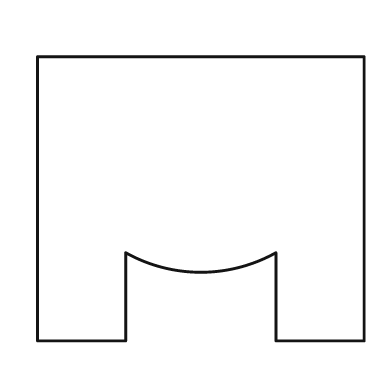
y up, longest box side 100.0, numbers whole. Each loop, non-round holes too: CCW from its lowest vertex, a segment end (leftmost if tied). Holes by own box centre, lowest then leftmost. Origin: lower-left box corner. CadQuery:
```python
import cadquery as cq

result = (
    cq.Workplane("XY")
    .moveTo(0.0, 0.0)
    .lineTo(27.0, 0.0)
    .lineTo(27.0, 27.0)
    .threePointArc((50.0, 21.0), (73.0, 27.0))
    .lineTo(73.0, 0.0)
    .lineTo(100.0, 0.0)
    .lineTo(100.0, 87.0)
    .lineTo(0.0, 87.0)
    .close()
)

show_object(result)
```